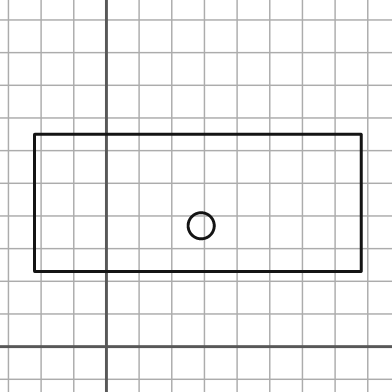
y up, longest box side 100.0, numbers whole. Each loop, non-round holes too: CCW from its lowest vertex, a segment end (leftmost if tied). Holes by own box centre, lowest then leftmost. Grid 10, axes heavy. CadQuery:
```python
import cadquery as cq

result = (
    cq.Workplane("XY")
    .moveTo(-22.0, 23.0)
    .lineTo(78.0, 23.0)
    .lineTo(78.0, 65.0)
    .lineTo(-22.0, 65.0)
    .close()
    .moveTo(29.0, 37.0)
    .circle(4.0)
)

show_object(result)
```